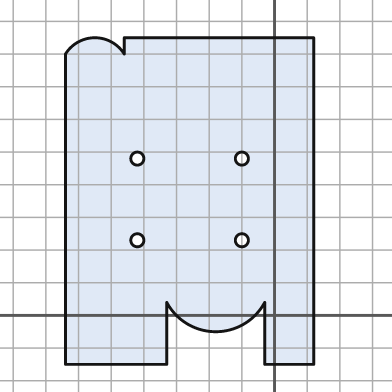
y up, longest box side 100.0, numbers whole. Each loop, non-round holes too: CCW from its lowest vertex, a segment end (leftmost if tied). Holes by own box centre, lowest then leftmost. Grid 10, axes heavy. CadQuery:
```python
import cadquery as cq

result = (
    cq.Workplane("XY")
    .moveTo(-64.0, -15.0)
    .lineTo(-33.0, -15.0)
    .lineTo(-33.0, 4.0)
    .threePointArc((-18.0, -5.0), (-3.0, 4.0))
    .lineTo(-3.0, -15.0)
    .lineTo(12.0, -15.0)
    .lineTo(12.0, 85.0)
    .lineTo(-46.0, 85.0)
    .lineTo(-46.0, 80.0)
    .threePointArc((-55.0, 85.0), (-64.0, 80.0))
    .close()
    .moveTo(-42.0, 23.0)
    .circle(2.0)
    .moveTo(-10.0, 23.0)
    .circle(2.0)
    .moveTo(-42.0, 48.0)
    .circle(2.0)
    .moveTo(-10.0, 48.0)
    .circle(2.0)
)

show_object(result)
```